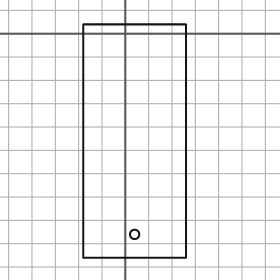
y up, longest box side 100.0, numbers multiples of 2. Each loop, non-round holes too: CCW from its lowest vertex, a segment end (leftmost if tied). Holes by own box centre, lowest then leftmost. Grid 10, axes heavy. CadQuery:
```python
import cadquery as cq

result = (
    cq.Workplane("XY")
    .moveTo(-18.0, -96.0)
    .lineTo(26.0, -96.0)
    .lineTo(26.0, 4.0)
    .lineTo(-18.0, 4.0)
    .close()
    .moveTo(4.0, -86.0)
    .circle(2.0)
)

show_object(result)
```